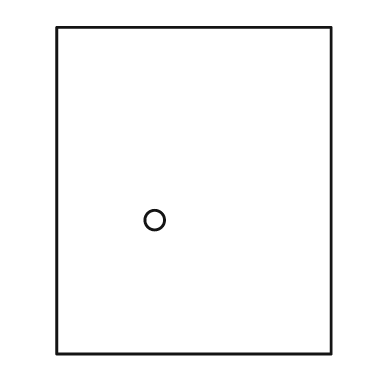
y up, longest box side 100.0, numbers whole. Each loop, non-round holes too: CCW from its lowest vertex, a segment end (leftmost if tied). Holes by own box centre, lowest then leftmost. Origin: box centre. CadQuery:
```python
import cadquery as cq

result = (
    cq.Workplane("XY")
    .moveTo(-42.0, -50.0)
    .lineTo(42.0, -50.0)
    .lineTo(42.0, 50.0)
    .lineTo(-42.0, 50.0)
    .close()
    .moveTo(-12.0, -9.0)
    .circle(3.0)
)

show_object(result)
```